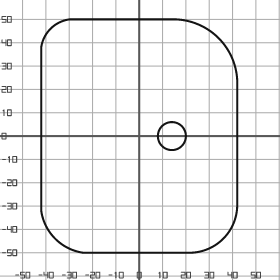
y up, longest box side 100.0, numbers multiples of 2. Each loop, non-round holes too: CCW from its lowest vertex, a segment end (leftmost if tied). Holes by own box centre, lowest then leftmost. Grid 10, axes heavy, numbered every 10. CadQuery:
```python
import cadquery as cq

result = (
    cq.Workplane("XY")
    .moveTo(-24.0, -50.0)
    .lineTo(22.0, -50.0)
    .threePointArc((36.0, -44.0), (42.0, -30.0))
    .lineTo(42.0, 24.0)
    .threePointArc((34.0, 42.0), (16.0, 50.0))
    .lineTo(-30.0, 50.0)
    .threePointArc((-38.0, 46.0), (-42.0, 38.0))
    .lineTo(-42.0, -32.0)
    .threePointArc((-36.0, -44.0), (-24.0, -50.0))
    .close()
    .moveTo(14.0, 0.0)
    .circle(6.0)
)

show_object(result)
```